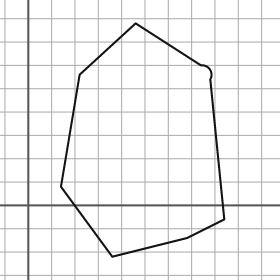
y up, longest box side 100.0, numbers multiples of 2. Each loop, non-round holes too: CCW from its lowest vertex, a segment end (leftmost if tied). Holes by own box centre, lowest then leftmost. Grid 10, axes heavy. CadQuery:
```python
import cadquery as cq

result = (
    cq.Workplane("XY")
    .moveTo(36.0, -22.0)
    .lineTo(68.0, -14.0)
    .lineTo(84.0, -6.0)
    .lineTo(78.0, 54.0)
    .threePointArc((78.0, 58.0), (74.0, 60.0))
    .lineTo(46.0, 78.0)
    .lineTo(22.0, 56.0)
    .lineTo(14.0, 8.0)
    .close()
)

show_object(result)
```